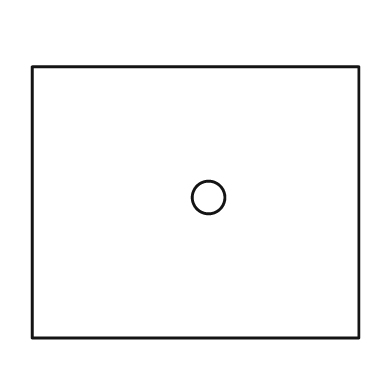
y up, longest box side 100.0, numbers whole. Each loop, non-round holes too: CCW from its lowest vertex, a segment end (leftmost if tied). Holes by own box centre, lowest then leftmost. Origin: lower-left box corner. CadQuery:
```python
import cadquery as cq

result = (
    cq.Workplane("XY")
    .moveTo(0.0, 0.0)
    .lineTo(100.0, 0.0)
    .lineTo(100.0, 83.0)
    .lineTo(0.0, 83.0)
    .close()
    .moveTo(54.0, 43.0)
    .circle(5.0)
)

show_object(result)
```